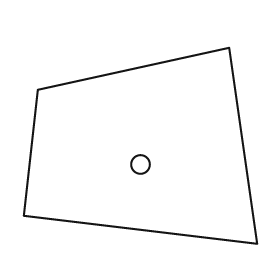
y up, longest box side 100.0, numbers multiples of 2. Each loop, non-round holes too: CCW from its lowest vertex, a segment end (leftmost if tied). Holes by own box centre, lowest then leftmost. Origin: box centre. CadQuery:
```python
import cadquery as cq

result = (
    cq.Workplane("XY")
    .moveTo(50.0, -42.0)
    .lineTo(38.0, 42.0)
    .lineTo(-44.0, 24.0)
    .lineTo(-50.0, -30.0)
    .close()
    .moveTo(0.0, -8.0)
    .circle(4.0)
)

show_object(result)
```